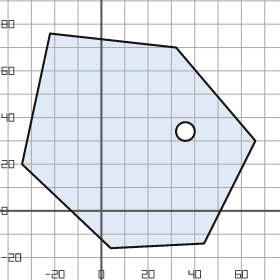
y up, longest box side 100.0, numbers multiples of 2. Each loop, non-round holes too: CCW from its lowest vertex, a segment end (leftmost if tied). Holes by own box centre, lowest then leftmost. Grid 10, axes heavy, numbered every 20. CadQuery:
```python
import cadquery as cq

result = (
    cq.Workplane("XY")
    .moveTo(4.0, -16.0)
    .lineTo(44.0, -14.0)
    .lineTo(66.0, 30.0)
    .lineTo(32.0, 70.0)
    .lineTo(-22.0, 76.0)
    .lineTo(-34.0, 20.0)
    .close()
    .moveTo(36.0, 34.0)
    .circle(4.0)
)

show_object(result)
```